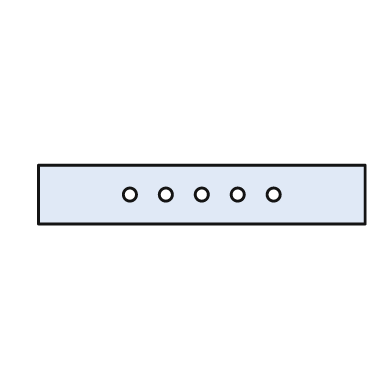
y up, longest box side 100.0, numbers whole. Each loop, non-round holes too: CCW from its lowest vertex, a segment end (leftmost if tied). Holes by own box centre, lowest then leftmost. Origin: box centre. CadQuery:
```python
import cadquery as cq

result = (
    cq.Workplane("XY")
    .moveTo(-50.0, -9.0)
    .lineTo(50.0, -9.0)
    .lineTo(50.0, 9.0)
    .lineTo(-50.0, 9.0)
    .close()
    .moveTo(-22.0, 0.0)
    .circle(2.0)
    .moveTo(-11.0, 0.0)
    .circle(2.0)
    .moveTo(0.0, 0.0)
    .circle(2.0)
    .moveTo(11.0, 0.0)
    .circle(2.0)
    .moveTo(22.0, 0.0)
    .circle(2.0)
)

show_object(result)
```